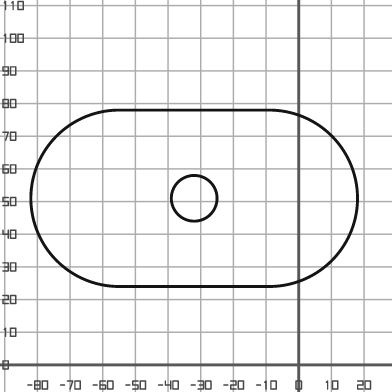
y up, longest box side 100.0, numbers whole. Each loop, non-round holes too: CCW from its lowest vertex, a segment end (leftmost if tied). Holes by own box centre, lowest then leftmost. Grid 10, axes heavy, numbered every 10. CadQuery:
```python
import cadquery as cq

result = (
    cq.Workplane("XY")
    .moveTo(-55.0, 24.0)
    .lineTo(-9.0, 24.0)
    .threePointArc((18.0, 51.0), (-9.0, 78.0))
    .lineTo(-55.0, 78.0)
    .threePointArc((-82.0, 51.0), (-55.0, 24.0))
    .close()
    .moveTo(-32.0, 51.0)
    .circle(7.0)
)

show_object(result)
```